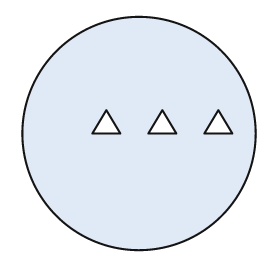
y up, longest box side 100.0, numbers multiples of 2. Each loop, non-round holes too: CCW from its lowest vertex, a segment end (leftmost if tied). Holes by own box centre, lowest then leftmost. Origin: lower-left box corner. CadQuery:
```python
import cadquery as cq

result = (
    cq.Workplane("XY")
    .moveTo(50.0, 50.0)
    .circle(50.0)
    .moveTo(30.0, 50.0)
    .lineTo(42.0, 50.0)
    .lineTo(36.0, 60.0)
    .close()
    .moveTo(54.0, 50.0)
    .lineTo(66.0, 50.0)
    .lineTo(60.0, 60.0)
    .close()
    .moveTo(78.0, 50.0)
    .lineTo(90.0, 50.0)
    .lineTo(84.0, 60.0)
    .close()
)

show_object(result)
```